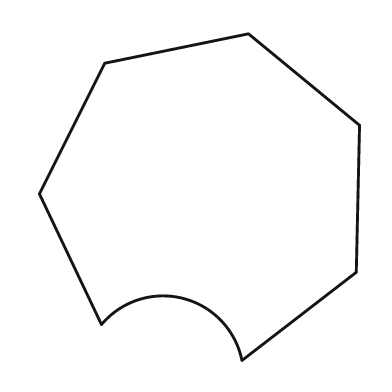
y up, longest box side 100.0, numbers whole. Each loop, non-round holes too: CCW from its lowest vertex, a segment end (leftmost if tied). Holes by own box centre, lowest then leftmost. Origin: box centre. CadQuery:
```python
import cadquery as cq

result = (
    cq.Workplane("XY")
    .moveTo(13.0, -50.0)
    .lineTo(48.0, -23.0)
    .lineTo(49.0, 22.0)
    .lineTo(15.0, 50.0)
    .lineTo(-29.0, 41.0)
    .lineTo(-49.0, 1.0)
    .lineTo(-30.0, -39.0)
    .threePointArc((-5.0, -31.0), (13.0, -50.0))
    .close()
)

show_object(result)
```